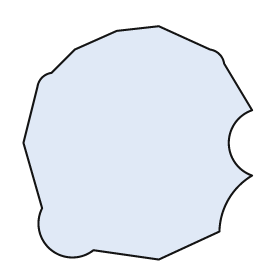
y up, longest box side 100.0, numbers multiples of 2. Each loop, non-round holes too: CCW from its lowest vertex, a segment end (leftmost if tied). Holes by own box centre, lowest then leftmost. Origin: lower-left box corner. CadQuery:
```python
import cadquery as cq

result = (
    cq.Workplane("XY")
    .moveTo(58.0, 0.0)
    .lineTo(84.0, 12.0)
    .threePointArc((88.0, 26.0), (98.0, 36.0))
    .threePointArc((88.0, 50.0), (98.0, 64.0))
    .lineTo(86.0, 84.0)
    .threePointArc((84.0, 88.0), (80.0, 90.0))
    .lineTo(58.0, 100.0)
    .lineTo(40.0, 98.0)
    .lineTo(22.0, 90.0)
    .lineTo(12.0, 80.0)
    .threePointArc((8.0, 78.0), (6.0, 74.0))
    .lineTo(0.0, 50.0)
    .lineTo(8.0, 22.0)
    .threePointArc((12.0, 4.0), (30.0, 4.0))
    .close()
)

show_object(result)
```